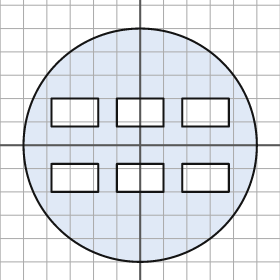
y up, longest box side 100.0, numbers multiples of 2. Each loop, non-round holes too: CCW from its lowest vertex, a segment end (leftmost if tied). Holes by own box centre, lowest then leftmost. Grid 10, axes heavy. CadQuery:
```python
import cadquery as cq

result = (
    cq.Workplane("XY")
    .moveTo(0.0, 0.0)
    .circle(50.0)
    .moveTo(-38.0, -20.0)
    .lineTo(-18.0, -20.0)
    .lineTo(-18.0, -8.0)
    .lineTo(-38.0, -8.0)
    .close()
    .moveTo(-10.0, -20.0)
    .lineTo(10.0, -20.0)
    .lineTo(10.0, -8.0)
    .lineTo(-10.0, -8.0)
    .close()
    .moveTo(18.0, -20.0)
    .lineTo(38.0, -20.0)
    .lineTo(38.0, -8.0)
    .lineTo(18.0, -8.0)
    .close()
    .moveTo(-38.0, 8.0)
    .lineTo(-18.0, 8.0)
    .lineTo(-18.0, 20.0)
    .lineTo(-38.0, 20.0)
    .close()
    .moveTo(-10.0, 8.0)
    .lineTo(10.0, 8.0)
    .lineTo(10.0, 20.0)
    .lineTo(-10.0, 20.0)
    .close()
    .moveTo(18.0, 8.0)
    .lineTo(38.0, 8.0)
    .lineTo(38.0, 20.0)
    .lineTo(18.0, 20.0)
    .close()
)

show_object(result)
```